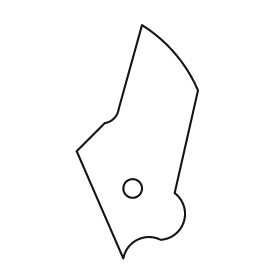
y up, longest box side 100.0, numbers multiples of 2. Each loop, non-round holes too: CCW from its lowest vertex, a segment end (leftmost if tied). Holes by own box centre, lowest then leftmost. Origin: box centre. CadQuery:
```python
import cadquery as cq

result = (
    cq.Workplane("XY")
    .moveTo(-6.0, -50.0)
    .threePointArc((0.0, -42.0), (10.0, -42.0))
    .threePointArc((20.0, -34.0), (16.0, -22.0))
    .lineTo(26.0, 22.0)
    .threePointArc((16.0, 38.0), (2.0, 50.0))
    .lineTo(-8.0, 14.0)
    .threePointArc((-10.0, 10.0), (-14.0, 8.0))
    .lineTo(-26.0, -4.0)
    .close()
    .moveTo(-2.0, -20.0)
    .circle(4.0)
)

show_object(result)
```